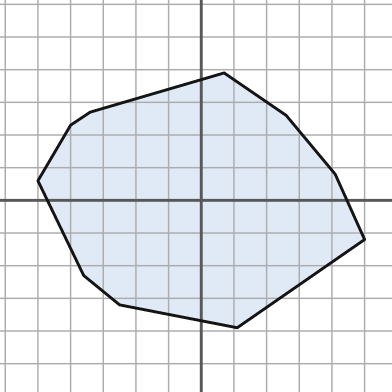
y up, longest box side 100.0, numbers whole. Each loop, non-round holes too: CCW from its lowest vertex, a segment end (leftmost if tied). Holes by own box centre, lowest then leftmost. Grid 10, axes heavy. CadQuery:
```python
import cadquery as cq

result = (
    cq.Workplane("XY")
    .moveTo(11.0, -39.0)
    .lineTo(50.0, -12.0)
    .lineTo(41.0, 8.0)
    .lineTo(26.0, 26.0)
    .lineTo(7.0, 39.0)
    .lineTo(-34.0, 27.0)
    .lineTo(-40.0, 23.0)
    .lineTo(-50.0, 6.0)
    .lineTo(-36.0, -23.0)
    .lineTo(-25.0, -32.0)
    .close()
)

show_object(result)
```